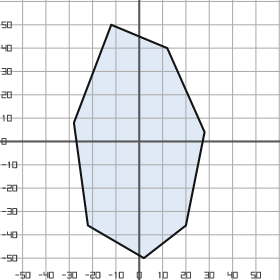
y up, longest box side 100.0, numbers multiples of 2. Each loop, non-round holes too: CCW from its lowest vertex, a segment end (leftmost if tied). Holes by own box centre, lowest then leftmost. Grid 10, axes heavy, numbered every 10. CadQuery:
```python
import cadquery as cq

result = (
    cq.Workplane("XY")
    .moveTo(2.0, -50.0)
    .lineTo(20.0, -36.0)
    .lineTo(28.0, 4.0)
    .lineTo(12.0, 40.0)
    .lineTo(-12.0, 50.0)
    .lineTo(-28.0, 8.0)
    .lineTo(-22.0, -36.0)
    .close()
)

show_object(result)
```